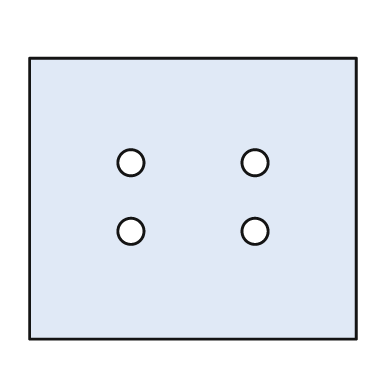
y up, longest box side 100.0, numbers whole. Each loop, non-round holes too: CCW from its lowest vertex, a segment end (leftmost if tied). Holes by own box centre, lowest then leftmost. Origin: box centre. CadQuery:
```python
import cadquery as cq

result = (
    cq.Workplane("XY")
    .moveTo(-50.0, -43.0)
    .lineTo(50.0, -43.0)
    .lineTo(50.0, 43.0)
    .lineTo(-50.0, 43.0)
    .close()
    .moveTo(-19.0, -10.0)
    .circle(4.0)
    .moveTo(19.0, -10.0)
    .circle(4.0)
    .moveTo(-19.0, 11.0)
    .circle(4.0)
    .moveTo(19.0, 11.0)
    .circle(4.0)
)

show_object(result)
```